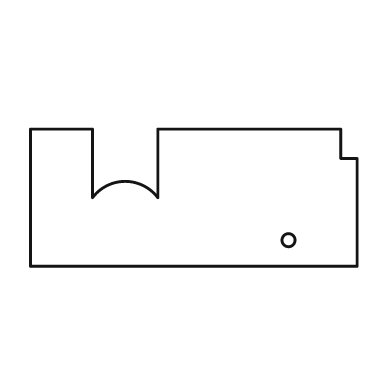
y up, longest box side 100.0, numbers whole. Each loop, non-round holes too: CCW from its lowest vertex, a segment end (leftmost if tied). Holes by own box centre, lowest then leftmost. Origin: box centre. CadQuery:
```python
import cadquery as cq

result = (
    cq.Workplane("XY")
    .moveTo(-50.0, -21.0)
    .lineTo(50.0, -21.0)
    .lineTo(50.0, 12.0)
    .lineTo(45.0, 12.0)
    .lineTo(45.0, 21.0)
    .lineTo(-11.0, 21.0)
    .lineTo(-11.0, 0.0)
    .threePointArc((-21.0, 5.0), (-31.0, 0.0))
    .lineTo(-31.0, 21.0)
    .lineTo(-50.0, 21.0)
    .close()
    .moveTo(29.0, -13.0)
    .circle(2.0)
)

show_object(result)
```